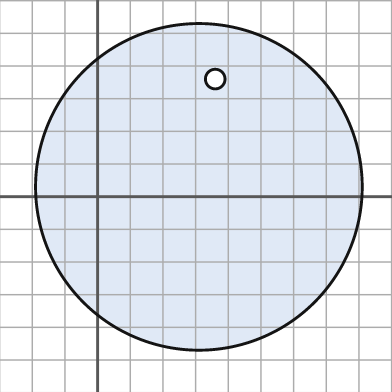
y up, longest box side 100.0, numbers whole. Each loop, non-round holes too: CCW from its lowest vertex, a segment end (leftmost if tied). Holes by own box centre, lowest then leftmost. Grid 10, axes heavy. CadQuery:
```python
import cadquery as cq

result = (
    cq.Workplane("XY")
    .moveTo(31.0, 3.0)
    .circle(50.0)
    .moveTo(36.0, 36.0)
    .circle(3.0)
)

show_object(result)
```